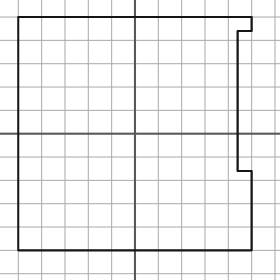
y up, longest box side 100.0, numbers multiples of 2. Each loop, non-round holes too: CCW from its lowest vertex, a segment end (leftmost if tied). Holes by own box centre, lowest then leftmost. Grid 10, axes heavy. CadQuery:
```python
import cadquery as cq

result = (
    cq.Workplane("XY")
    .moveTo(-50.0, -50.0)
    .lineTo(50.0, -50.0)
    .lineTo(50.0, -16.0)
    .lineTo(44.0, -16.0)
    .lineTo(44.0, 44.0)
    .lineTo(50.0, 44.0)
    .lineTo(50.0, 50.0)
    .lineTo(-50.0, 50.0)
    .close()
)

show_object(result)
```